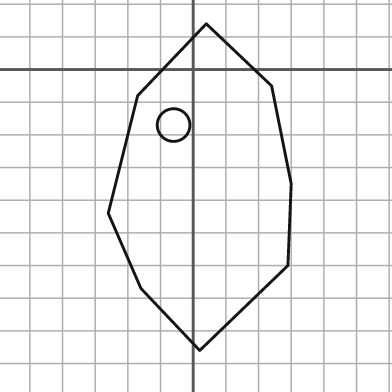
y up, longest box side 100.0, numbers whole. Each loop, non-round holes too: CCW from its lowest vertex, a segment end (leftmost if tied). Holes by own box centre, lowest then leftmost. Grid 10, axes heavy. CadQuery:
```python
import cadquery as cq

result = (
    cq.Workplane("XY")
    .moveTo(2.0, -86.0)
    .lineTo(29.0, -60.0)
    .lineTo(30.0, -35.0)
    .lineTo(24.0, -5.0)
    .lineTo(4.0, 14.0)
    .lineTo(-17.0, -8.0)
    .lineTo(-26.0, -44.0)
    .lineTo(-16.0, -67.0)
    .close()
    .moveTo(-6.0, -17.0)
    .circle(5.0)
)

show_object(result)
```